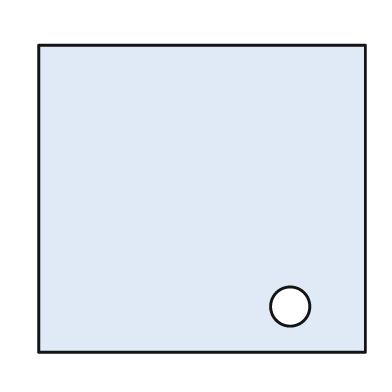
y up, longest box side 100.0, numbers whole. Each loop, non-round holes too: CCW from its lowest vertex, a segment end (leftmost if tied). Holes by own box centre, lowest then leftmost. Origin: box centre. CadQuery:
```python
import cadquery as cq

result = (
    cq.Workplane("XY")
    .moveTo(-50.0, -47.0)
    .lineTo(50.0, -47.0)
    .lineTo(50.0, 47.0)
    .lineTo(-50.0, 47.0)
    .close()
    .moveTo(27.0, -33.0)
    .circle(6.0)
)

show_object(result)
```